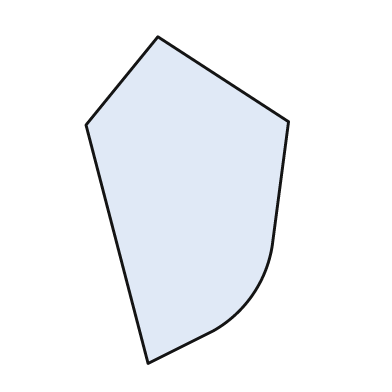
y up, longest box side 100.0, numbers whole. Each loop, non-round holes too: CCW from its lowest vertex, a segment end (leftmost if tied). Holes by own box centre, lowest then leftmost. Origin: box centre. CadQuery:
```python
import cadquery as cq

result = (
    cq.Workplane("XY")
    .moveTo(-12.0, -50.0)
    .lineTo(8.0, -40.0)
    .threePointArc((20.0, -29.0), (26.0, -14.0))
    .lineTo(31.0, 24.0)
    .lineTo(-9.0, 50.0)
    .lineTo(-31.0, 23.0)
    .close()
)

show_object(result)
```